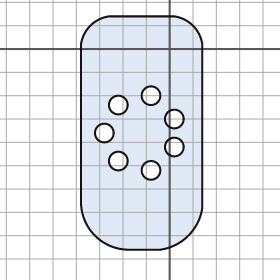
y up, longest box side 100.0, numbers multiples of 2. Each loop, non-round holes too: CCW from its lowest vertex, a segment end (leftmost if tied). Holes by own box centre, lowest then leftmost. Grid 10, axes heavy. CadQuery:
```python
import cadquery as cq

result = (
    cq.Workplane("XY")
    .moveTo(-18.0, -86.0)
    .lineTo(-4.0, -86.0)
    .threePointArc((8.0, -80.0), (14.0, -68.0))
    .lineTo(14.0, 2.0)
    .threePointArc((10.0, 10.0), (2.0, 14.0))
    .lineTo(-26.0, 14.0)
    .threePointArc((-34.0, 10.0), (-38.0, 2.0))
    .lineTo(-38.0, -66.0)
    .threePointArc((-32.0, -80.0), (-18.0, -86.0))
    .close()
    .moveTo(-8.0, -52.0)
    .circle(4.0)
    .moveTo(-22.0, -48.0)
    .circle(4.0)
    .moveTo(2.0, -42.0)
    .circle(4.0)
    .moveTo(-28.0, -36.0)
    .circle(4.0)
    .moveTo(2.0, -30.0)
    .circle(4.0)
    .moveTo(-22.0, -24.0)
    .circle(4.0)
    .moveTo(-8.0, -20.0)
    .circle(4.0)
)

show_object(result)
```